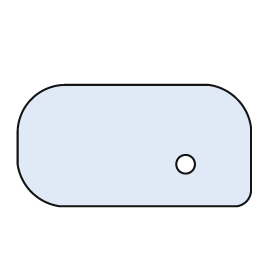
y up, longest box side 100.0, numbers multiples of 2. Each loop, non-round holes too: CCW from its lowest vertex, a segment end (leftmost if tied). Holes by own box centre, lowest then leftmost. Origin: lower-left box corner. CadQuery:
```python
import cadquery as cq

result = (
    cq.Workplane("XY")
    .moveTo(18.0, 0.0)
    .lineTo(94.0, 0.0)
    .threePointArc((98.0, 2.0), (100.0, 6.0))
    .lineTo(100.0, 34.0)
    .threePointArc((94.0, 46.0), (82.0, 52.0))
    .lineTo(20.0, 52.0)
    .threePointArc((6.0, 46.0), (0.0, 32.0))
    .lineTo(0.0, 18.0)
    .threePointArc((6.0, 6.0), (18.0, 0.0))
    .close()
    .moveTo(72.0, 18.0)
    .circle(4.0)
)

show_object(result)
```